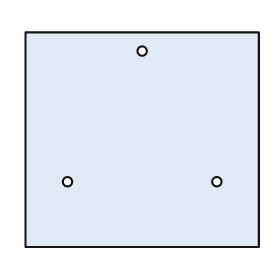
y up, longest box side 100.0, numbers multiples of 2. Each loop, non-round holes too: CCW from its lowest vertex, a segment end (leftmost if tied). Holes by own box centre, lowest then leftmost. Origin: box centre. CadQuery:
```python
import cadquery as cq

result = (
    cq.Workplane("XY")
    .moveTo(-50.0, -46.0)
    .lineTo(50.0, -46.0)
    .lineTo(50.0, 46.0)
    .lineTo(-50.0, 46.0)
    .close()
    .moveTo(-32.0, -18.0)
    .circle(2.0)
    .moveTo(32.0, -18.0)
    .circle(2.0)
    .moveTo(0.0, 38.0)
    .circle(2.0)
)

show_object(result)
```